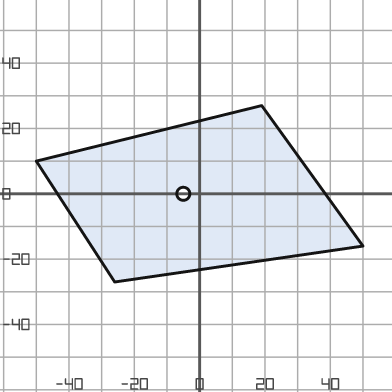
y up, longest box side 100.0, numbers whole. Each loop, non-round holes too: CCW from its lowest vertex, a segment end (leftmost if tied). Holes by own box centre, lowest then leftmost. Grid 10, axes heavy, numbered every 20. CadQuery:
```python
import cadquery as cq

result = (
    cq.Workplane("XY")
    .moveTo(-26.0, -27.0)
    .lineTo(50.0, -16.0)
    .lineTo(19.0, 27.0)
    .lineTo(-50.0, 10.0)
    .close()
    .moveTo(-5.0, 0.0)
    .circle(2.0)
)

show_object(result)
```